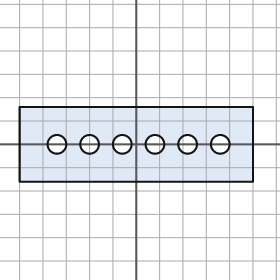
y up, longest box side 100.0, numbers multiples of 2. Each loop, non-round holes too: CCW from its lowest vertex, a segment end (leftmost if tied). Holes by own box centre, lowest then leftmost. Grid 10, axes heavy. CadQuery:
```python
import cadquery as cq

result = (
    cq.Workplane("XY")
    .moveTo(-50.0, -16.0)
    .lineTo(50.0, -16.0)
    .lineTo(50.0, 16.0)
    .lineTo(-50.0, 16.0)
    .close()
    .moveTo(-34.0, 0.0)
    .circle(4.0)
    .moveTo(-20.0, 0.0)
    .circle(4.0)
    .moveTo(-6.0, 0.0)
    .circle(4.0)
    .moveTo(8.0, 0.0)
    .circle(4.0)
    .moveTo(22.0, 0.0)
    .circle(4.0)
    .moveTo(36.0, 0.0)
    .circle(4.0)
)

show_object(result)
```